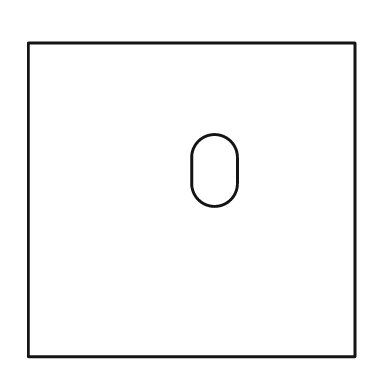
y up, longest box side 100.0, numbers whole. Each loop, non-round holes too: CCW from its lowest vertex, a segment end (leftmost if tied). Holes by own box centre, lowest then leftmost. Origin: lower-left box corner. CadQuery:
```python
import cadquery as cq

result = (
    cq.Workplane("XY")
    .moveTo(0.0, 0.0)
    .lineTo(100.0, 0.0)
    .lineTo(100.0, 96.0)
    .lineTo(0.0, 96.0)
    .close()
    .moveTo(50.0, 53.0)
    .threePointArc((57.0, 46.0), (64.0, 53.0))
    .lineTo(64.0, 61.0)
    .threePointArc((57.0, 68.0), (50.0, 61.0))
    .close()
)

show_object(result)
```